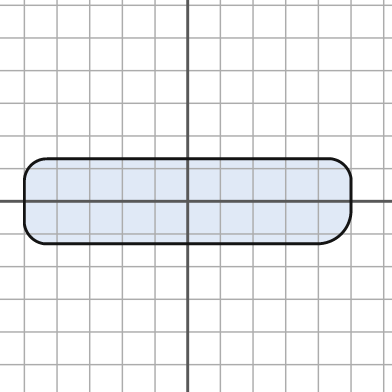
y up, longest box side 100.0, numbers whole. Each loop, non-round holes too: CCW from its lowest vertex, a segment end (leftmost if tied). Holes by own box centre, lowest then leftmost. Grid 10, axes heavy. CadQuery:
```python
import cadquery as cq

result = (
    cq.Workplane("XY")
    .moveTo(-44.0, -13.0)
    .lineTo(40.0, -13.0)
    .threePointArc((47.0, -10.0), (50.0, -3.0))
    .lineTo(50.0, 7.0)
    .threePointArc((48.0, 11.0), (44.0, 13.0))
    .lineTo(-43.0, 13.0)
    .threePointArc((-48.0, 11.0), (-50.0, 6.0))
    .lineTo(-50.0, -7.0)
    .threePointArc((-48.0, -11.0), (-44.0, -13.0))
    .close()
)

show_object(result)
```